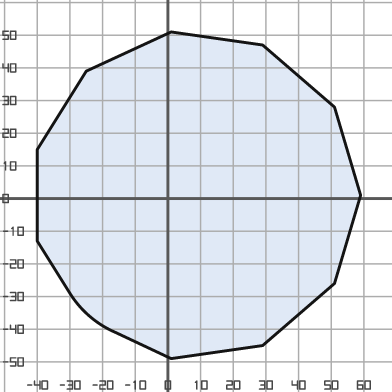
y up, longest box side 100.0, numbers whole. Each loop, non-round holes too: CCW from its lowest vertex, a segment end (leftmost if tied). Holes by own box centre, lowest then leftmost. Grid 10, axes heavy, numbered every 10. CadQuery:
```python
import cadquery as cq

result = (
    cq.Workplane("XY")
    .moveTo(1.0, -49.0)
    .lineTo(29.0, -45.0)
    .lineTo(51.0, -26.0)
    .lineTo(59.0, 1.0)
    .lineTo(51.0, 28.0)
    .lineTo(29.0, 47.0)
    .lineTo(1.0, 51.0)
    .lineTo(-25.0, 39.0)
    .lineTo(-40.0, 15.0)
    .lineTo(-40.0, -13.0)
    .lineTo(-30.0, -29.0)
    .threePointArc((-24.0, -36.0), (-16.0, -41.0))
    .close()
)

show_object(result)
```